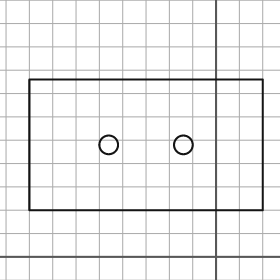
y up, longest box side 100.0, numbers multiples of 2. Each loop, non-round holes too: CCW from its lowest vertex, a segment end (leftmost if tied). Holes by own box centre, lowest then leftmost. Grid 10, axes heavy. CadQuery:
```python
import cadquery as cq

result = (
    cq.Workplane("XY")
    .moveTo(-80.0, 20.0)
    .lineTo(20.0, 20.0)
    .lineTo(20.0, 76.0)
    .lineTo(-80.0, 76.0)
    .close()
    .moveTo(-46.0, 48.0)
    .circle(4.0)
    .moveTo(-14.0, 48.0)
    .circle(4.0)
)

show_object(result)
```